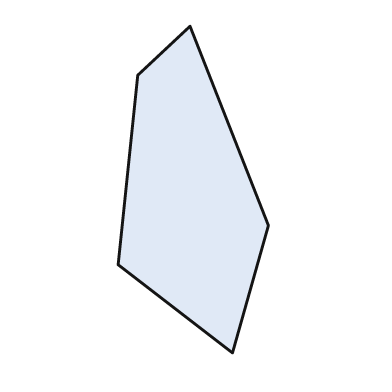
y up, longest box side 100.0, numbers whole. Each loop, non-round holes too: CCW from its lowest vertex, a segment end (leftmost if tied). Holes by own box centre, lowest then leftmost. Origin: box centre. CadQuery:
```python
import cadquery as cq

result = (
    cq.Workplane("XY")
    .moveTo(12.0, -50.0)
    .lineTo(23.0, -11.0)
    .lineTo(-1.0, 50.0)
    .lineTo(-17.0, 35.0)
    .lineTo(-23.0, -23.0)
    .close()
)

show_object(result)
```